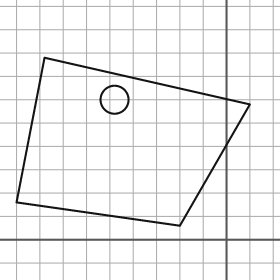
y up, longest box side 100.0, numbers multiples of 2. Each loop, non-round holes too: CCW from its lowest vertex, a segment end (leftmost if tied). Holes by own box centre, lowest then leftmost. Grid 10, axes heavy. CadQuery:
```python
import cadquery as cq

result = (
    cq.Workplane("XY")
    .moveTo(-20.0, 6.0)
    .lineTo(10.0, 58.0)
    .lineTo(-78.0, 78.0)
    .lineTo(-90.0, 16.0)
    .close()
    .moveTo(-48.0, 60.0)
    .circle(6.0)
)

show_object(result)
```